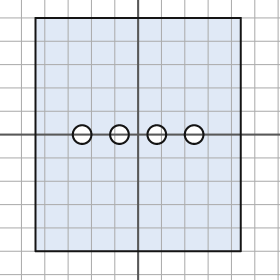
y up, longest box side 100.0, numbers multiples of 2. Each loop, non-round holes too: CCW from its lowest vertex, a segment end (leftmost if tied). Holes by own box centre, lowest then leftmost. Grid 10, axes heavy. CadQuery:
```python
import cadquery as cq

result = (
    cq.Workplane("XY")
    .moveTo(-44.0, -50.0)
    .lineTo(44.0, -50.0)
    .lineTo(44.0, 50.0)
    .lineTo(-44.0, 50.0)
    .close()
    .moveTo(-24.0, 0.0)
    .circle(4.0)
    .moveTo(-8.0, 0.0)
    .circle(4.0)
    .moveTo(8.0, 0.0)
    .circle(4.0)
    .moveTo(24.0, 0.0)
    .circle(4.0)
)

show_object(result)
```